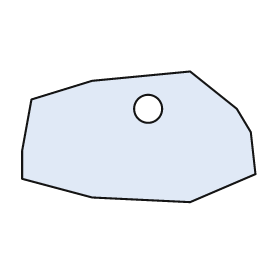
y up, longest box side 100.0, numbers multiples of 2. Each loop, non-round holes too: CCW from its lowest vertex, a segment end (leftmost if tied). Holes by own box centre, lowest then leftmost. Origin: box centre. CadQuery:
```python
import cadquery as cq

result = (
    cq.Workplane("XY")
    .moveTo(22.0, -28.0)
    .lineTo(50.0, -16.0)
    .lineTo(48.0, 2.0)
    .lineTo(42.0, 12.0)
    .lineTo(22.0, 28.0)
    .lineTo(-20.0, 24.0)
    .lineTo(-46.0, 16.0)
    .lineTo(-50.0, -6.0)
    .lineTo(-50.0, -18.0)
    .lineTo(-20.0, -26.0)
    .close()
    .moveTo(4.0, 12.0)
    .circle(6.0)
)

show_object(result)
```